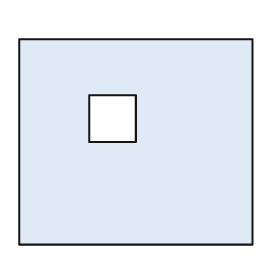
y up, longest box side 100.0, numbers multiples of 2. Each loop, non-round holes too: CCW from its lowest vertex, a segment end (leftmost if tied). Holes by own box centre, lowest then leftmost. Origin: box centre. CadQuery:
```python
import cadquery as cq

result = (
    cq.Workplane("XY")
    .moveTo(-50.0, -44.0)
    .lineTo(50.0, -44.0)
    .lineTo(50.0, 44.0)
    .lineTo(-50.0, 44.0)
    .close()
    .moveTo(-20.0, 0.0)
    .lineTo(0.0, 0.0)
    .lineTo(0.0, 20.0)
    .lineTo(-20.0, 20.0)
    .close()
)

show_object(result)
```